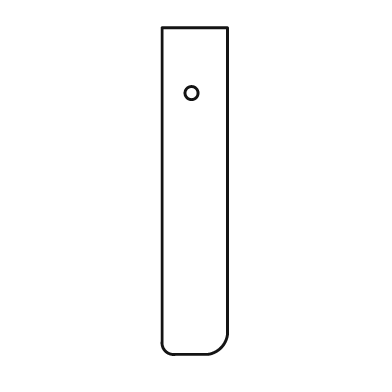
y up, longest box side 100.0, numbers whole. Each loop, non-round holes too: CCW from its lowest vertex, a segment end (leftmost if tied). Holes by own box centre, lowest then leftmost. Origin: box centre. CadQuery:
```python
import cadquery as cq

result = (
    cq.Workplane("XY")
    .moveTo(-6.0, -50.0)
    .lineTo(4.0, -50.0)
    .threePointArc((8.0, -48.0), (10.0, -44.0))
    .lineTo(10.0, 50.0)
    .lineTo(-10.0, 50.0)
    .lineTo(-10.0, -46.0)
    .threePointArc((-9.0, -49.0), (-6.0, -50.0))
    .close()
    .moveTo(-1.0, 30.0)
    .circle(2.0)
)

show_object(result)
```